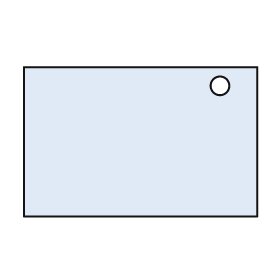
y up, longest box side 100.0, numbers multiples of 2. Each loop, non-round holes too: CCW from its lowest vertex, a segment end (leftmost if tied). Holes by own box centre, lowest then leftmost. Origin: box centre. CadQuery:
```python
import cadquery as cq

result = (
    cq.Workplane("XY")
    .moveTo(-50.0, -32.0)
    .lineTo(50.0, -32.0)
    .lineTo(50.0, 32.0)
    .lineTo(-50.0, 32.0)
    .close()
    .moveTo(34.0, 24.0)
    .circle(4.0)
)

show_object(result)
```